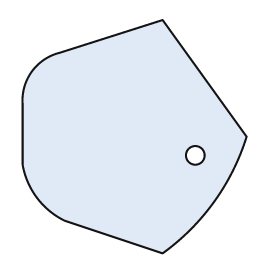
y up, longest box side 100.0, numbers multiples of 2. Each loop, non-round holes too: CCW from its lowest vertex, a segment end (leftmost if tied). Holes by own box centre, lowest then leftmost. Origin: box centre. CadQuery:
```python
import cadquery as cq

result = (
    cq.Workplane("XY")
    .moveTo(12.0, -50.0)
    .threePointArc((34.0, -28.0), (48.0, 0.0))
    .lineTo(12.0, 50.0)
    .lineTo(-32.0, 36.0)
    .threePointArc((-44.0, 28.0), (-48.0, 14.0))
    .lineTo(-48.0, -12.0)
    .threePointArc((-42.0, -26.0), (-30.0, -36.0))
    .close()
    .moveTo(26.0, -8.0)
    .circle(4.0)
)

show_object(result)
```